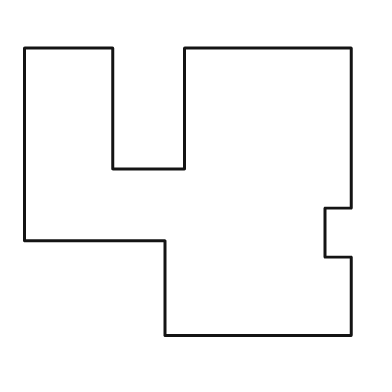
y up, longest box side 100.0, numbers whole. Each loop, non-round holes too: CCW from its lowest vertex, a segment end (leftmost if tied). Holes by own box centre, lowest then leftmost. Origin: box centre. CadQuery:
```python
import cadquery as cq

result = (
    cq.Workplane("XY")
    .moveTo(-7.0, -44.0)
    .lineTo(50.0, -44.0)
    .lineTo(50.0, -20.0)
    .lineTo(42.0, -20.0)
    .lineTo(42.0, -5.0)
    .lineTo(50.0, -5.0)
    .lineTo(50.0, 44.0)
    .lineTo(-1.0, 44.0)
    .lineTo(-1.0, 7.0)
    .lineTo(-23.0, 7.0)
    .lineTo(-23.0, 44.0)
    .lineTo(-50.0, 44.0)
    .lineTo(-50.0, -15.0)
    .lineTo(-7.0, -15.0)
    .close()
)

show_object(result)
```